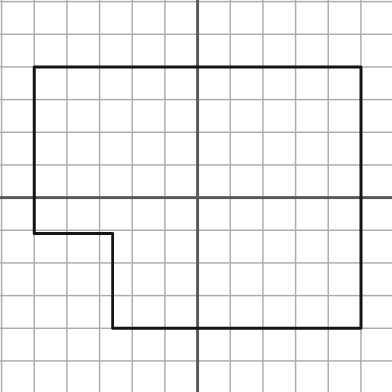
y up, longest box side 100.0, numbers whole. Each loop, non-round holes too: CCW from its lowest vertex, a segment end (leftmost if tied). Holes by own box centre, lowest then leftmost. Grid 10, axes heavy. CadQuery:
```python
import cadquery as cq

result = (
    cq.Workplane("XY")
    .moveTo(-26.0, -40.0)
    .lineTo(50.0, -40.0)
    .lineTo(50.0, 40.0)
    .lineTo(-50.0, 40.0)
    .lineTo(-50.0, -11.0)
    .lineTo(-26.0, -11.0)
    .close()
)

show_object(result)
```